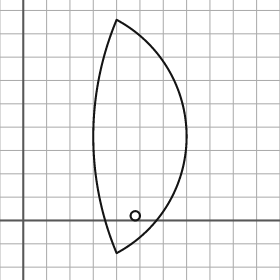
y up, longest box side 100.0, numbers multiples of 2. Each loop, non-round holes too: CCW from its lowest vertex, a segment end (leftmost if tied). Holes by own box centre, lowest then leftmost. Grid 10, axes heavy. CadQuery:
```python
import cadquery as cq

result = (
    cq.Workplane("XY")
    .moveTo(40.0, -14.0)
    .threePointArc((70.0, 36.0), (40.0, 86.0))
    .threePointArc((30.0, 36.0), (40.0, -14.0))
    .close()
    .moveTo(48.0, 2.0)
    .circle(2.0)
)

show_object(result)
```